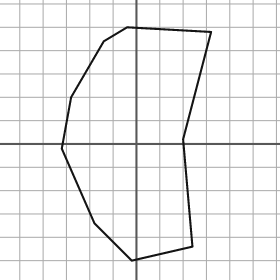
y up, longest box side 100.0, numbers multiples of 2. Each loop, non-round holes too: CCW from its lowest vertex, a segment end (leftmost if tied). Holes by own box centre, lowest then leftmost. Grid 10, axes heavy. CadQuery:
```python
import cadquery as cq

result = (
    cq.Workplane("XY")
    .moveTo(-2.0, -50.0)
    .lineTo(24.0, -44.0)
    .lineTo(20.0, 2.0)
    .lineTo(32.0, 48.0)
    .lineTo(-4.0, 50.0)
    .lineTo(-14.0, 44.0)
    .lineTo(-28.0, 20.0)
    .lineTo(-32.0, -2.0)
    .lineTo(-18.0, -34.0)
    .close()
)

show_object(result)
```